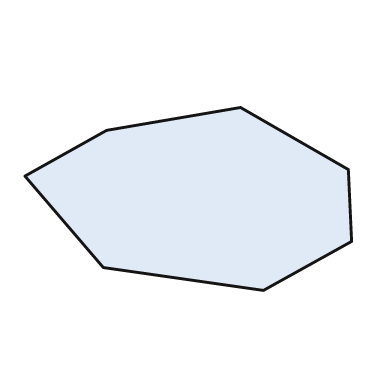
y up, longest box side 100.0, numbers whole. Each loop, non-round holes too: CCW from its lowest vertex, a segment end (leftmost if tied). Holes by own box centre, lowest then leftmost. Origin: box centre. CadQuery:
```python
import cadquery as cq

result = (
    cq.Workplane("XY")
    .moveTo(23.0, -28.0)
    .lineTo(50.0, -13.0)
    .lineTo(49.0, 9.0)
    .lineTo(16.0, 28.0)
    .lineTo(-25.0, 21.0)
    .lineTo(-50.0, 7.0)
    .lineTo(-26.0, -21.0)
    .close()
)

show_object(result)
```